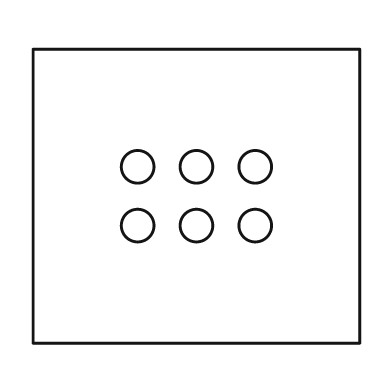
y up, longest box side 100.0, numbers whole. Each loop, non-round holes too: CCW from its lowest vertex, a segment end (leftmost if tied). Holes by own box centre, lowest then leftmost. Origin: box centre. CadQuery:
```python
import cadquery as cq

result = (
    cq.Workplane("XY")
    .moveTo(-50.0, -45.0)
    .lineTo(50.0, -45.0)
    .lineTo(50.0, 45.0)
    .lineTo(-50.0, 45.0)
    .close()
    .moveTo(-18.0, -9.0)
    .circle(5.0)
    .moveTo(0.0, -9.0)
    .circle(5.0)
    .moveTo(18.0, -9.0)
    .circle(5.0)
    .moveTo(-18.0, 9.0)
    .circle(5.0)
    .moveTo(0.0, 9.0)
    .circle(5.0)
    .moveTo(18.0, 9.0)
    .circle(5.0)
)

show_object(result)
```